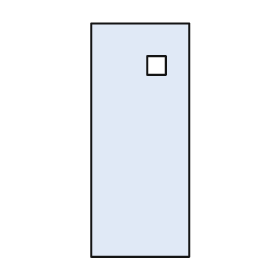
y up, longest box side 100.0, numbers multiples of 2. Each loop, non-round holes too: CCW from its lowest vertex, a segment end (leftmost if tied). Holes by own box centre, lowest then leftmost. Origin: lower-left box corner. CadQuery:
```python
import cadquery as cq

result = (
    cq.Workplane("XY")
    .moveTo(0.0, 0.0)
    .lineTo(42.0, 0.0)
    .lineTo(42.0, 100.0)
    .lineTo(0.0, 100.0)
    .close()
    .moveTo(24.0, 78.0)
    .lineTo(32.0, 78.0)
    .lineTo(32.0, 86.0)
    .lineTo(24.0, 86.0)
    .close()
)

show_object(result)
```